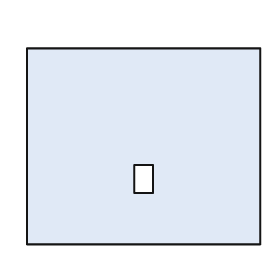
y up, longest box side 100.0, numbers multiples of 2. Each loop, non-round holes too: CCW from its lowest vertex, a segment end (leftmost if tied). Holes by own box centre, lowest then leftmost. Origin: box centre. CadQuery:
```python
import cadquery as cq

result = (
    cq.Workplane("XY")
    .moveTo(-50.0, -42.0)
    .lineTo(50.0, -42.0)
    .lineTo(50.0, 42.0)
    .lineTo(-50.0, 42.0)
    .close()
    .moveTo(-4.0, -20.0)
    .lineTo(4.0, -20.0)
    .lineTo(4.0, -8.0)
    .lineTo(-4.0, -8.0)
    .close()
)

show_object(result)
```